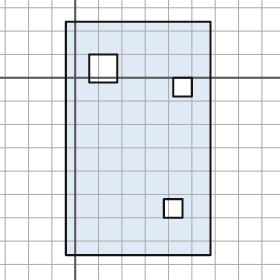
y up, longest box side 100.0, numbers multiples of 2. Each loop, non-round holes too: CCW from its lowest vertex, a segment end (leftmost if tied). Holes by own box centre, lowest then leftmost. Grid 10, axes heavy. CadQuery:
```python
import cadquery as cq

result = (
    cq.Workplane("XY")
    .moveTo(-4.0, -76.0)
    .lineTo(58.0, -76.0)
    .lineTo(58.0, 24.0)
    .lineTo(-4.0, 24.0)
    .close()
    .moveTo(38.0, -60.0)
    .lineTo(46.0, -60.0)
    .lineTo(46.0, -52.0)
    .lineTo(38.0, -52.0)
    .close()
    .moveTo(42.0, -8.0)
    .lineTo(50.0, -8.0)
    .lineTo(50.0, 0.0)
    .lineTo(42.0, 0.0)
    .close()
    .moveTo(6.0, -2.0)
    .lineTo(18.0, -2.0)
    .lineTo(18.0, 10.0)
    .lineTo(6.0, 10.0)
    .close()
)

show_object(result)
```